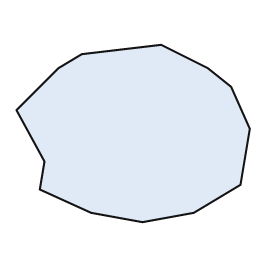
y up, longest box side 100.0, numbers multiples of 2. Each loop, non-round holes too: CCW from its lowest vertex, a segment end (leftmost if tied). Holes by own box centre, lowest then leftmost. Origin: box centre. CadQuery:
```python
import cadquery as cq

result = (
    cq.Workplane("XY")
    .moveTo(4.0, -38.0)
    .lineTo(26.0, -34.0)
    .lineTo(46.0, -22.0)
    .lineTo(50.0, 2.0)
    .lineTo(42.0, 20.0)
    .lineTo(32.0, 28.0)
    .lineTo(12.0, 38.0)
    .lineTo(-22.0, 34.0)
    .lineTo(-32.0, 28.0)
    .lineTo(-50.0, 10.0)
    .lineTo(-38.0, -12.0)
    .lineTo(-40.0, -24.0)
    .lineTo(-18.0, -34.0)
    .close()
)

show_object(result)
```